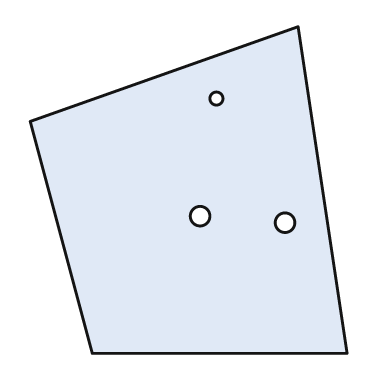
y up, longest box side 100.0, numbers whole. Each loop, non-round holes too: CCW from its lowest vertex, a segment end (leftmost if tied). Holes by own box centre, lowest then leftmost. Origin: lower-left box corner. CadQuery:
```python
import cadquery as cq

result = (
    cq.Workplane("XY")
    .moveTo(19.0, 0.0)
    .lineTo(97.0, 0.0)
    .lineTo(82.0, 100.0)
    .lineTo(0.0, 71.0)
    .close()
    .moveTo(78.0, 40.0)
    .circle(3.0)
    .moveTo(52.0, 42.0)
    .circle(3.0)
    .moveTo(57.0, 78.0)
    .circle(2.0)
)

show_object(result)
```